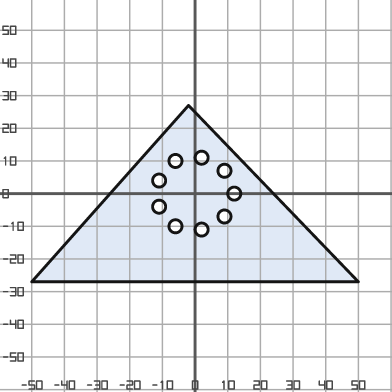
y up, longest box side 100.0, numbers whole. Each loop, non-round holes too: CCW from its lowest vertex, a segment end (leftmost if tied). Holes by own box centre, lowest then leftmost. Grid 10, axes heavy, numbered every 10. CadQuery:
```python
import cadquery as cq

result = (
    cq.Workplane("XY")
    .moveTo(-50.0, -27.0)
    .lineTo(50.0, -27.0)
    .lineTo(-2.0, 27.0)
    .close()
    .moveTo(2.0, -11.0)
    .circle(2.0)
    .moveTo(-6.0, -10.0)
    .circle(2.0)
    .moveTo(9.0, -7.0)
    .circle(2.0)
    .moveTo(-11.0, -4.0)
    .circle(2.0)
    .moveTo(12.0, 0.0)
    .circle(2.0)
    .moveTo(-11.0, 4.0)
    .circle(2.0)
    .moveTo(9.0, 7.0)
    .circle(2.0)
    .moveTo(-6.0, 10.0)
    .circle(2.0)
    .moveTo(2.0, 11.0)
    .circle(2.0)
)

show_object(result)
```